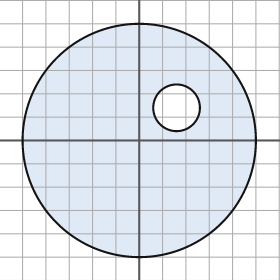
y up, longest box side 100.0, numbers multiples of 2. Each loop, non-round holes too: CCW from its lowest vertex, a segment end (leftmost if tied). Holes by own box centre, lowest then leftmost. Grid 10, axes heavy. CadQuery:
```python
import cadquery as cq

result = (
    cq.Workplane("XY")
    .moveTo(0.0, 0.0)
    .circle(50.0)
    .moveTo(16.0, 14.0)
    .circle(10.0)
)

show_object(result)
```